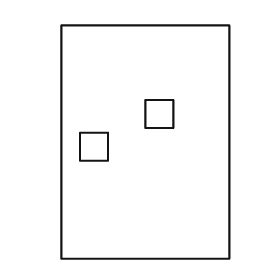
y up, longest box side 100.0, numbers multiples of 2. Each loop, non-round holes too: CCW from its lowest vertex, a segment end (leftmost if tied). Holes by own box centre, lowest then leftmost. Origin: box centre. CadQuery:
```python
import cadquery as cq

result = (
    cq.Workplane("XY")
    .moveTo(-36.0, -50.0)
    .lineTo(36.0, -50.0)
    .lineTo(36.0, 50.0)
    .lineTo(-36.0, 50.0)
    .close()
    .moveTo(-28.0, -8.0)
    .lineTo(-16.0, -8.0)
    .lineTo(-16.0, 4.0)
    .lineTo(-28.0, 4.0)
    .close()
    .moveTo(0.0, 6.0)
    .lineTo(12.0, 6.0)
    .lineTo(12.0, 18.0)
    .lineTo(0.0, 18.0)
    .close()
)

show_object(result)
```